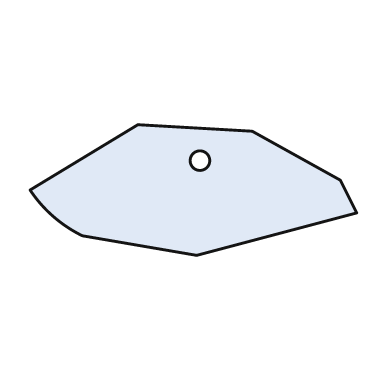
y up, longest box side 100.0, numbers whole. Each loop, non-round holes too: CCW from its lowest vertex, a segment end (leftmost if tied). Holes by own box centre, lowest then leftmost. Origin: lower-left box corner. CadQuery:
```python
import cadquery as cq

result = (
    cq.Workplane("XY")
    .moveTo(51.0, 0.0)
    .lineTo(100.0, 13.0)
    .lineTo(95.0, 23.0)
    .lineTo(68.0, 38.0)
    .lineTo(33.0, 40.0)
    .lineTo(0.0, 20.0)
    .threePointArc((7.0, 12.0), (16.0, 6.0))
    .close()
    .moveTo(52.0, 29.0)
    .circle(3.0)
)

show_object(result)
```